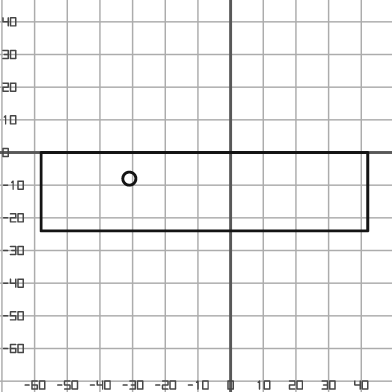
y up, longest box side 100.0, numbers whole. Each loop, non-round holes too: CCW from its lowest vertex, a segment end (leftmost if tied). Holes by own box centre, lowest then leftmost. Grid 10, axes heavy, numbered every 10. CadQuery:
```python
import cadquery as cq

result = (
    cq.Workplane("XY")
    .moveTo(-58.0, -24.0)
    .lineTo(42.0, -24.0)
    .lineTo(42.0, 0.0)
    .lineTo(-58.0, 0.0)
    .close()
    .moveTo(-31.0, -8.0)
    .circle(2.0)
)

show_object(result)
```